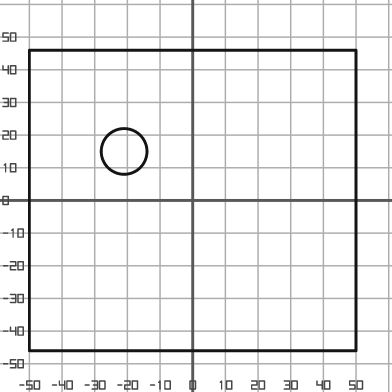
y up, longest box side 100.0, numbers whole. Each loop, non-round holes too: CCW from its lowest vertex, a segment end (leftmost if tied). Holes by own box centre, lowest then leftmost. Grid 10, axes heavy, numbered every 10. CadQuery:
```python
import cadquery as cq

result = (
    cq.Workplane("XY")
    .moveTo(-50.0, -46.0)
    .lineTo(50.0, -46.0)
    .lineTo(50.0, 46.0)
    .lineTo(-50.0, 46.0)
    .close()
    .moveTo(-21.0, 15.0)
    .circle(7.0)
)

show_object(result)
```